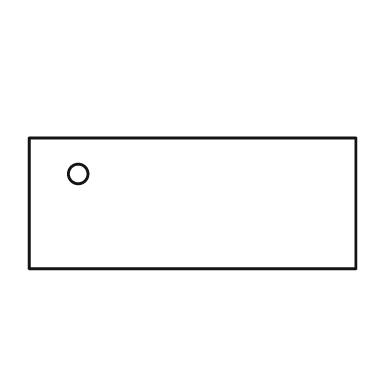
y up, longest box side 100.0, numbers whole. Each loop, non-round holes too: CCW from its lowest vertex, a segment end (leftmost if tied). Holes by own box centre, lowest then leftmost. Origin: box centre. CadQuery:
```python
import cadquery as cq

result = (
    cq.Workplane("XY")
    .moveTo(-50.0, -20.0)
    .lineTo(50.0, -20.0)
    .lineTo(50.0, 20.0)
    .lineTo(-50.0, 20.0)
    .close()
    .moveTo(-35.0, 9.0)
    .circle(3.0)
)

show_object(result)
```